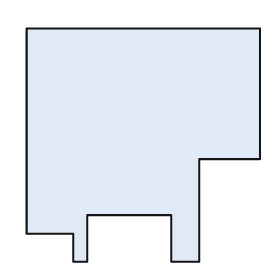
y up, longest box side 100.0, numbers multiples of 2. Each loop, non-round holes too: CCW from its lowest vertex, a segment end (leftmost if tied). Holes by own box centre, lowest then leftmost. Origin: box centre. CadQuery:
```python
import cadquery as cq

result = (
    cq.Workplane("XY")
    .moveTo(-30.0, -50.0)
    .lineTo(-24.0, -50.0)
    .lineTo(-24.0, -30.0)
    .lineTo(12.0, -30.0)
    .lineTo(12.0, -50.0)
    .lineTo(24.0, -50.0)
    .lineTo(24.0, -6.0)
    .lineTo(50.0, -6.0)
    .lineTo(50.0, 50.0)
    .lineTo(-50.0, 50.0)
    .lineTo(-50.0, -38.0)
    .lineTo(-30.0, -38.0)
    .close()
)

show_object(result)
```